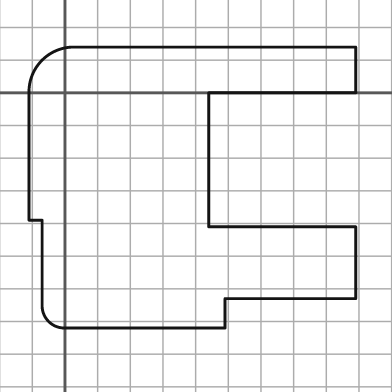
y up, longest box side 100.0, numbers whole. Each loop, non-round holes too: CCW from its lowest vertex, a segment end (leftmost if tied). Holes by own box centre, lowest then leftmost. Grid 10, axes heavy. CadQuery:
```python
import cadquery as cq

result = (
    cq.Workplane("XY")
    .moveTo(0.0, -72.0)
    .lineTo(49.0, -72.0)
    .lineTo(49.0, -63.0)
    .lineTo(89.0, -63.0)
    .lineTo(89.0, -41.0)
    .lineTo(44.0, -41.0)
    .lineTo(44.0, 0.0)
    .lineTo(89.0, 0.0)
    .lineTo(89.0, 14.0)
    .lineTo(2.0, 14.0)
    .threePointArc((-7.0, 10.0), (-11.0, 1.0))
    .lineTo(-11.0, -39.0)
    .lineTo(-7.0, -39.0)
    .lineTo(-7.0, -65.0)
    .threePointArc((-5.0, -70.0), (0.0, -72.0))
    .close()
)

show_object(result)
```